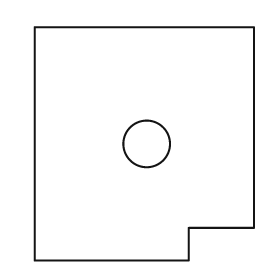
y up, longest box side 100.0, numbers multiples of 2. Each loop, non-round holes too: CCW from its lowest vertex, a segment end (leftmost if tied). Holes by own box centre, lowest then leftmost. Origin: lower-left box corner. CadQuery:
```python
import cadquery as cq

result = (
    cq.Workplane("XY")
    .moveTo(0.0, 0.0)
    .lineTo(66.0, 0.0)
    .lineTo(66.0, 14.0)
    .lineTo(94.0, 14.0)
    .lineTo(94.0, 100.0)
    .lineTo(0.0, 100.0)
    .close()
    .moveTo(48.0, 50.0)
    .circle(10.0)
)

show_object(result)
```